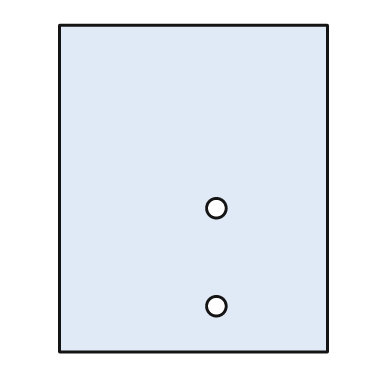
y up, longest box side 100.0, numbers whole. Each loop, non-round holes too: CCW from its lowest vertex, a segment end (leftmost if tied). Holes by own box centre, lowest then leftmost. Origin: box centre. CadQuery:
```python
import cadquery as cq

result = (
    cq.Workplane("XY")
    .moveTo(-41.0, -50.0)
    .lineTo(41.0, -50.0)
    .lineTo(41.0, 50.0)
    .lineTo(-41.0, 50.0)
    .close()
    .moveTo(7.0, -36.0)
    .circle(3.0)
    .moveTo(7.0, -6.0)
    .circle(3.0)
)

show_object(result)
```